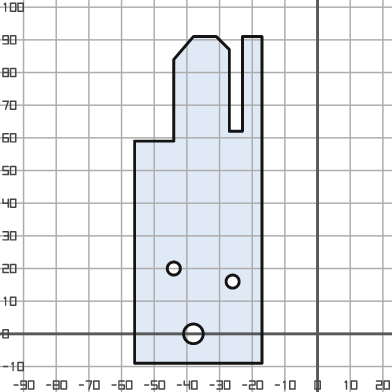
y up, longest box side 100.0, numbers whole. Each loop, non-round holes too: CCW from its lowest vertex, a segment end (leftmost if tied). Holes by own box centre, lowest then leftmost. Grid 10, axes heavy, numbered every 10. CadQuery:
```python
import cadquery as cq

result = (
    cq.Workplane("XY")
    .moveTo(-56.0, -9.0)
    .lineTo(-17.0, -9.0)
    .lineTo(-17.0, 91.0)
    .lineTo(-23.0, 91.0)
    .lineTo(-23.0, 62.0)
    .lineTo(-27.0, 62.0)
    .lineTo(-27.0, 87.0)
    .lineTo(-31.0, 91.0)
    .lineTo(-38.0, 91.0)
    .lineTo(-44.0, 84.0)
    .lineTo(-44.0, 59.0)
    .lineTo(-56.0, 59.0)
    .close()
    .moveTo(-38.0, 0.0)
    .circle(3.0)
    .moveTo(-26.0, 16.0)
    .circle(2.0)
    .moveTo(-44.0, 20.0)
    .circle(2.0)
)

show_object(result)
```